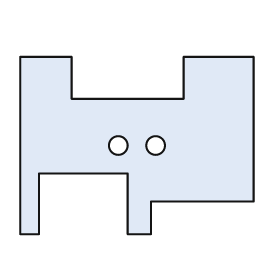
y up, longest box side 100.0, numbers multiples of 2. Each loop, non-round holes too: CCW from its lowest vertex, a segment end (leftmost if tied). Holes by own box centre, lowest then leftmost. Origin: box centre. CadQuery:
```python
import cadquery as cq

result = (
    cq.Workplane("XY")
    .moveTo(-50.0, -38.0)
    .lineTo(-42.0, -38.0)
    .lineTo(-42.0, -12.0)
    .lineTo(-4.0, -12.0)
    .lineTo(-4.0, -38.0)
    .lineTo(6.0, -38.0)
    .lineTo(6.0, -24.0)
    .lineTo(50.0, -24.0)
    .lineTo(50.0, 38.0)
    .lineTo(20.0, 38.0)
    .lineTo(20.0, 20.0)
    .lineTo(-28.0, 20.0)
    .lineTo(-28.0, 38.0)
    .lineTo(-50.0, 38.0)
    .close()
    .moveTo(-8.0, 0.0)
    .circle(4.0)
    .moveTo(8.0, 0.0)
    .circle(4.0)
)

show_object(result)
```